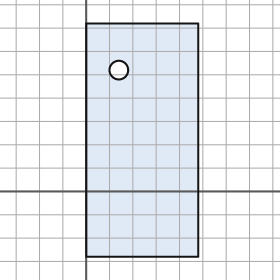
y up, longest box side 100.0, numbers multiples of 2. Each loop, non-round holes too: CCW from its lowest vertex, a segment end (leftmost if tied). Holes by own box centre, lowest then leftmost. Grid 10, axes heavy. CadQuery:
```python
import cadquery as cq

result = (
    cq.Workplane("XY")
    .moveTo(0.0, -28.0)
    .lineTo(48.0, -28.0)
    .lineTo(48.0, 72.0)
    .lineTo(0.0, 72.0)
    .close()
    .moveTo(14.0, 52.0)
    .circle(4.0)
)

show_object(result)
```